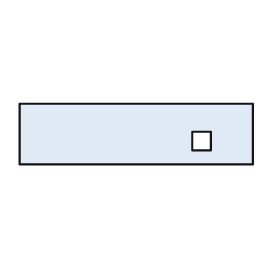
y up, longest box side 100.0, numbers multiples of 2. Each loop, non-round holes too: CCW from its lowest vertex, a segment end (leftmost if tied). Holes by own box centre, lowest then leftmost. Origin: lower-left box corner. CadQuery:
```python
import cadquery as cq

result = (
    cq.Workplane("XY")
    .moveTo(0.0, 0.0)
    .lineTo(100.0, 0.0)
    .lineTo(100.0, 26.0)
    .lineTo(0.0, 26.0)
    .close()
    .moveTo(74.0, 6.0)
    .lineTo(82.0, 6.0)
    .lineTo(82.0, 14.0)
    .lineTo(74.0, 14.0)
    .close()
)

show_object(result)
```